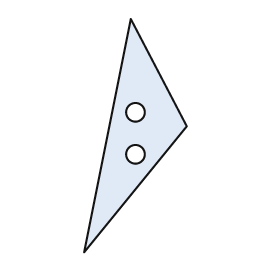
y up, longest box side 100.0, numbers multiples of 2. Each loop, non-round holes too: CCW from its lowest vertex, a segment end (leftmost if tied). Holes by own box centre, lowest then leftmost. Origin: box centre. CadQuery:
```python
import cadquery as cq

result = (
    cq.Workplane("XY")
    .moveTo(-22.0, -50.0)
    .lineTo(22.0, 4.0)
    .lineTo(-2.0, 50.0)
    .close()
    .moveTo(0.0, -8.0)
    .circle(4.0)
    .moveTo(0.0, 10.0)
    .circle(4.0)
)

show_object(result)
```